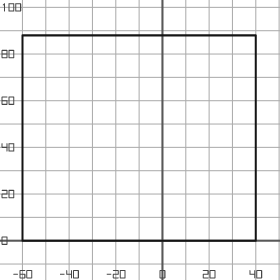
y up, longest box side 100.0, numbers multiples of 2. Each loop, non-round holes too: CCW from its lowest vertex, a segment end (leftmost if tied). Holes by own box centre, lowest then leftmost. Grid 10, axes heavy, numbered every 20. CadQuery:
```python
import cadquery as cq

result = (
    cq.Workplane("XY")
    .moveTo(-60.0, 0.0)
    .lineTo(40.0, 0.0)
    .lineTo(40.0, 88.0)
    .lineTo(-60.0, 88.0)
    .close()
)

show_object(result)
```